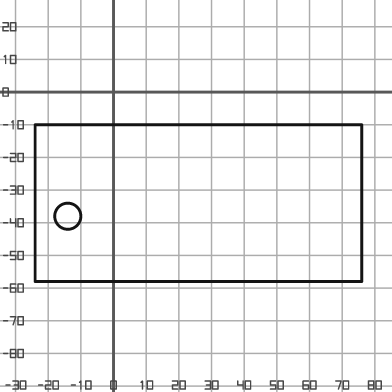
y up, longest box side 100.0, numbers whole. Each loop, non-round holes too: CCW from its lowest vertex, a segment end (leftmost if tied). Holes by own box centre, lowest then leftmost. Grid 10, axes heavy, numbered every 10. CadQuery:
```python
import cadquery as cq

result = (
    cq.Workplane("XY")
    .moveTo(-24.0, -58.0)
    .lineTo(76.0, -58.0)
    .lineTo(76.0, -10.0)
    .lineTo(-24.0, -10.0)
    .close()
    .moveTo(-14.0, -38.0)
    .circle(4.0)
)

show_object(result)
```